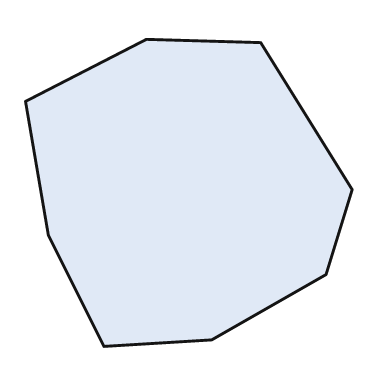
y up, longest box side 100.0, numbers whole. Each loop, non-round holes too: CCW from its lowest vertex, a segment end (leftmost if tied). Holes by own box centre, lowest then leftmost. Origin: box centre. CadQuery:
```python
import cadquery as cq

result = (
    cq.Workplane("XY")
    .moveTo(-26.0, -47.0)
    .lineTo(7.0, -45.0)
    .lineTo(42.0, -25.0)
    .lineTo(50.0, 1.0)
    .lineTo(22.0, 46.0)
    .lineTo(-13.0, 47.0)
    .lineTo(-50.0, 28.0)
    .lineTo(-43.0, -13.0)
    .close()
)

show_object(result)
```